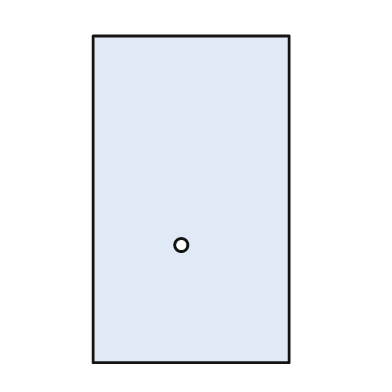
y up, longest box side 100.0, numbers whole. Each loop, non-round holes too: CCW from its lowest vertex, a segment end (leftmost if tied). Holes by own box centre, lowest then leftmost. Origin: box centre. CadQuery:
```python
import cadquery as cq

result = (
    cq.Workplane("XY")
    .moveTo(-30.0, -50.0)
    .lineTo(30.0, -50.0)
    .lineTo(30.0, 50.0)
    .lineTo(-30.0, 50.0)
    .close()
    .moveTo(-3.0, -14.0)
    .circle(2.0)
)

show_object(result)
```